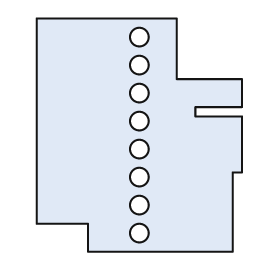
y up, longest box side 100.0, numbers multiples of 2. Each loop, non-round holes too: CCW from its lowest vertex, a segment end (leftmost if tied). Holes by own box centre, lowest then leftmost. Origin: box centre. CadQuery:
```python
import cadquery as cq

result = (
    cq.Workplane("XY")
    .moveTo(-22.0, -50.0)
    .lineTo(40.0, -50.0)
    .lineTo(40.0, -16.0)
    .lineTo(44.0, -16.0)
    .lineTo(44.0, 8.0)
    .lineTo(24.0, 8.0)
    .lineTo(24.0, 12.0)
    .lineTo(44.0, 12.0)
    .lineTo(44.0, 24.0)
    .lineTo(16.0, 24.0)
    .lineTo(16.0, 50.0)
    .lineTo(-44.0, 50.0)
    .lineTo(-44.0, -38.0)
    .lineTo(-22.0, -38.0)
    .close()
    .moveTo(0.0, -42.0)
    .circle(4.0)
    .moveTo(0.0, -30.0)
    .circle(4.0)
    .moveTo(0.0, -18.0)
    .circle(4.0)
    .moveTo(0.0, -6.0)
    .circle(4.0)
    .moveTo(0.0, 6.0)
    .circle(4.0)
    .moveTo(0.0, 18.0)
    .circle(4.0)
    .moveTo(0.0, 30.0)
    .circle(4.0)
    .moveTo(0.0, 42.0)
    .circle(4.0)
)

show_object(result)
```